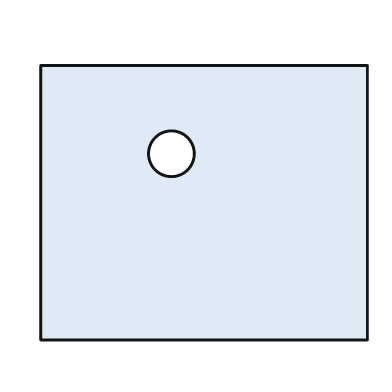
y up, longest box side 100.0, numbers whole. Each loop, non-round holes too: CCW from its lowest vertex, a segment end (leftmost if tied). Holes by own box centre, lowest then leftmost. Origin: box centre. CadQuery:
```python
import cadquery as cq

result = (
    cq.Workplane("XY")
    .moveTo(-50.0, -42.0)
    .lineTo(50.0, -42.0)
    .lineTo(50.0, 42.0)
    .lineTo(-50.0, 42.0)
    .close()
    .moveTo(-10.0, 15.0)
    .circle(7.0)
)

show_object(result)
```